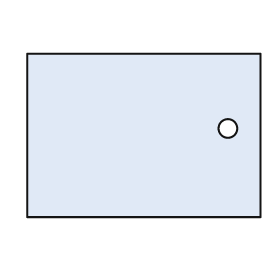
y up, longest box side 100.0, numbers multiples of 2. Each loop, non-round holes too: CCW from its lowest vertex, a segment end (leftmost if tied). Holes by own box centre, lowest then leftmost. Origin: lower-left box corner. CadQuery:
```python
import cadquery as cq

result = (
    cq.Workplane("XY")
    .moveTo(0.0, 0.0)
    .lineTo(100.0, 0.0)
    .lineTo(100.0, 70.0)
    .lineTo(0.0, 70.0)
    .close()
    .moveTo(86.0, 38.0)
    .circle(4.0)
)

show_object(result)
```